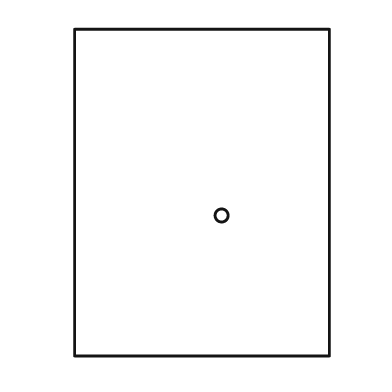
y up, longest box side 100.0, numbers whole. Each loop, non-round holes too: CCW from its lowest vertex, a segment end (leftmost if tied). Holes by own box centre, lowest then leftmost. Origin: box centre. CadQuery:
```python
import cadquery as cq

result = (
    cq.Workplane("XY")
    .moveTo(-39.0, -50.0)
    .lineTo(39.0, -50.0)
    .lineTo(39.0, 50.0)
    .lineTo(-39.0, 50.0)
    .close()
    .moveTo(6.0, -7.0)
    .circle(2.0)
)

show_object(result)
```